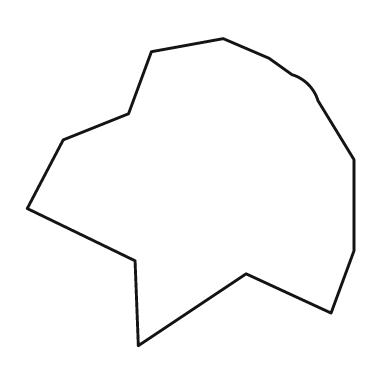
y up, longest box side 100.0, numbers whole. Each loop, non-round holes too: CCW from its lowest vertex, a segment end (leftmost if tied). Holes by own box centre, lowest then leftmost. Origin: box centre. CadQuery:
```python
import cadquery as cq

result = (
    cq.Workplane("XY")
    .moveTo(-16.0, -47.0)
    .lineTo(17.0, -25.0)
    .lineTo(43.0, -37.0)
    .lineTo(50.0, -18.0)
    .lineTo(50.0, 10.0)
    .lineTo(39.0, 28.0)
    .threePointArc((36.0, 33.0), (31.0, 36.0))
    .lineTo(24.0, 41.0)
    .lineTo(10.0, 47.0)
    .lineTo(-12.0, 43.0)
    .lineTo(-19.0, 24.0)
    .lineTo(-39.0, 16.0)
    .lineTo(-50.0, -5.0)
    .lineTo(-17.0, -21.0)
    .close()
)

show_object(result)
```